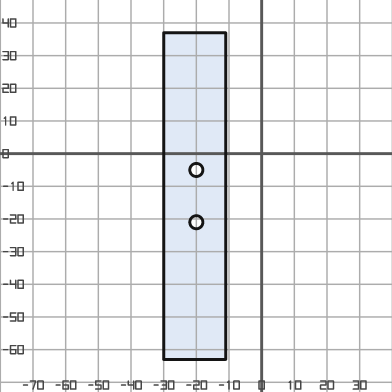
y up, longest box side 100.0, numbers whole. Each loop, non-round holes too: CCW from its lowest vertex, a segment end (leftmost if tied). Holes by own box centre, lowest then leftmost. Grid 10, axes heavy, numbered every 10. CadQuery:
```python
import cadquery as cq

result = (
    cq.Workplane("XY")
    .moveTo(-30.0, -63.0)
    .lineTo(-11.0, -63.0)
    .lineTo(-11.0, 37.0)
    .lineTo(-30.0, 37.0)
    .close()
    .moveTo(-20.0, -21.0)
    .circle(2.0)
    .moveTo(-20.0, -5.0)
    .circle(2.0)
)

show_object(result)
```